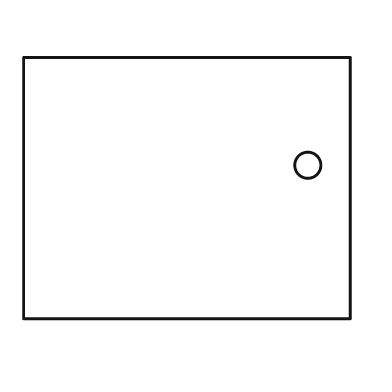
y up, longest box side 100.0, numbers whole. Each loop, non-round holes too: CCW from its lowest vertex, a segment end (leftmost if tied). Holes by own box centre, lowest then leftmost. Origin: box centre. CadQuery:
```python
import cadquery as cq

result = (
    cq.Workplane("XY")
    .moveTo(-50.0, -40.0)
    .lineTo(50.0, -40.0)
    .lineTo(50.0, 40.0)
    .lineTo(-50.0, 40.0)
    .close()
    .moveTo(37.0, 7.0)
    .circle(4.0)
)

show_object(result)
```